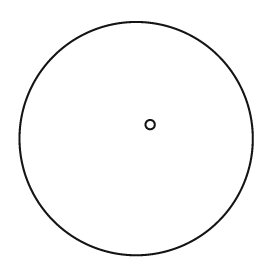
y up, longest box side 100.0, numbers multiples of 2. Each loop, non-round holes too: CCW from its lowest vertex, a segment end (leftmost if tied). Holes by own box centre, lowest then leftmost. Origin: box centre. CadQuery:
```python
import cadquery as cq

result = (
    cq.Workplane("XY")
    .moveTo(0.0, 0.0)
    .circle(50.0)
    .moveTo(6.0, 6.0)
    .circle(2.0)
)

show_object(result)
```